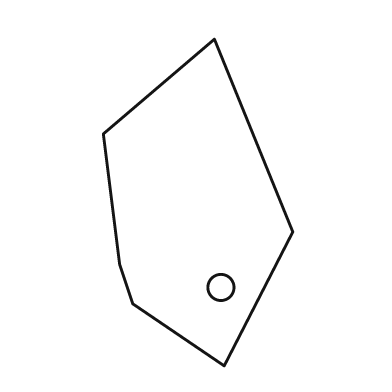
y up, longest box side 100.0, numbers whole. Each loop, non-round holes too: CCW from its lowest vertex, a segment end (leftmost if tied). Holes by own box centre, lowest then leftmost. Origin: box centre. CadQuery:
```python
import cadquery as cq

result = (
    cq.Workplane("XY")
    .moveTo(8.0, -50.0)
    .lineTo(29.0, -9.0)
    .lineTo(5.0, 50.0)
    .lineTo(-29.0, 21.0)
    .lineTo(-24.0, -19.0)
    .lineTo(-20.0, -31.0)
    .close()
    .moveTo(7.0, -26.0)
    .circle(4.0)
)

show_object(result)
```